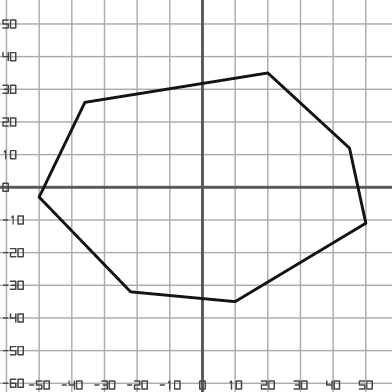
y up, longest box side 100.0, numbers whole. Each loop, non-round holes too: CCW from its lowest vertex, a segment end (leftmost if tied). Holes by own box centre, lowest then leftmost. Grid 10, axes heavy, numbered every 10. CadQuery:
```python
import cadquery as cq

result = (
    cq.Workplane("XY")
    .moveTo(10.0, -35.0)
    .lineTo(50.0, -11.0)
    .lineTo(45.0, 12.0)
    .lineTo(20.0, 35.0)
    .lineTo(-36.0, 26.0)
    .lineTo(-50.0, -3.0)
    .lineTo(-22.0, -32.0)
    .close()
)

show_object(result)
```